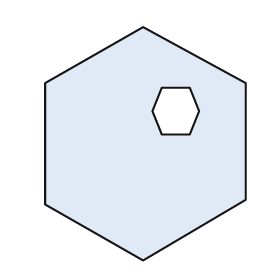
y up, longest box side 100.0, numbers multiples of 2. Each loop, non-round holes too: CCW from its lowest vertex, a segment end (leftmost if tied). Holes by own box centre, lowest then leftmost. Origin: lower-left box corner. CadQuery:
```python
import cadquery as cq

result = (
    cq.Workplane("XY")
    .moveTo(42.0, 0.0)
    .lineTo(86.0, 26.0)
    .lineTo(86.0, 76.0)
    .lineTo(42.0, 100.0)
    .lineTo(0.0, 76.0)
    .lineTo(0.0, 24.0)
    .close()
    .moveTo(50.0, 54.0)
    .lineTo(62.0, 54.0)
    .lineTo(66.0, 64.0)
    .lineTo(62.0, 74.0)
    .lineTo(50.0, 74.0)
    .lineTo(46.0, 64.0)
    .close()
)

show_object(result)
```